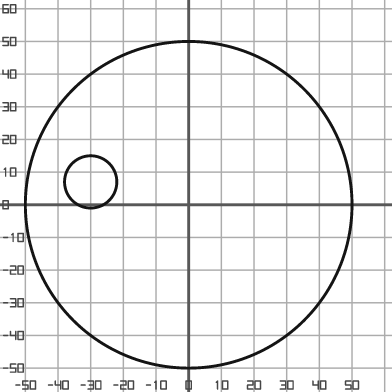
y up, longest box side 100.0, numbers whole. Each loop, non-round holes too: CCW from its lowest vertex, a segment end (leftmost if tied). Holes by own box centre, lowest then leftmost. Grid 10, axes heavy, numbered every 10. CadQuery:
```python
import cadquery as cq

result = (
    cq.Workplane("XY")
    .moveTo(0.0, 0.0)
    .circle(50.0)
    .moveTo(-30.0, 7.0)
    .circle(8.0)
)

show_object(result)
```